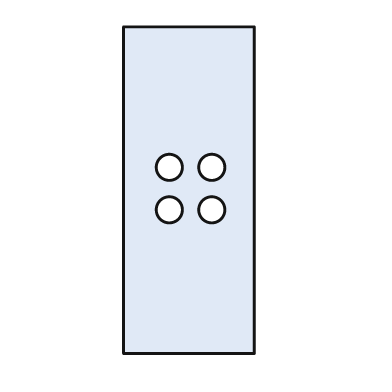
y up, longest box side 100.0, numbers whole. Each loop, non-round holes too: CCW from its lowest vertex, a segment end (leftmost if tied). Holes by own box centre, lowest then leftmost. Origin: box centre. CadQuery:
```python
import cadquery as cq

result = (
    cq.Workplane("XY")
    .moveTo(-20.0, -50.0)
    .lineTo(20.0, -50.0)
    .lineTo(20.0, 50.0)
    .lineTo(-20.0, 50.0)
    .close()
    .moveTo(-6.0, -6.0)
    .circle(4.0)
    .moveTo(7.0, -6.0)
    .circle(4.0)
    .moveTo(-6.0, 7.0)
    .circle(4.0)
    .moveTo(7.0, 7.0)
    .circle(4.0)
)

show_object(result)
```